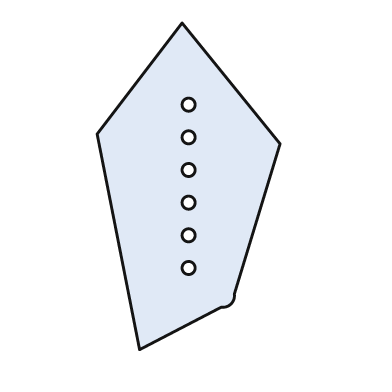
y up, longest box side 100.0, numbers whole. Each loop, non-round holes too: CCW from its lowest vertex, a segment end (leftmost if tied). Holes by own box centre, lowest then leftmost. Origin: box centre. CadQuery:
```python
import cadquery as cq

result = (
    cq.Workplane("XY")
    .moveTo(-15.0, -50.0)
    .lineTo(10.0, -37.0)
    .threePointArc((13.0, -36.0), (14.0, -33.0))
    .lineTo(28.0, 13.0)
    .lineTo(-2.0, 50.0)
    .lineTo(-28.0, 16.0)
    .close()
    .moveTo(0.0, -25.0)
    .circle(2.0)
    .moveTo(0.0, -15.0)
    .circle(2.0)
    .moveTo(0.0, -5.0)
    .circle(2.0)
    .moveTo(0.0, 5.0)
    .circle(2.0)
    .moveTo(0.0, 15.0)
    .circle(2.0)
    .moveTo(0.0, 25.0)
    .circle(2.0)
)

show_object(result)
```